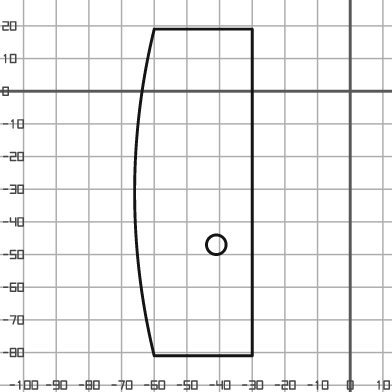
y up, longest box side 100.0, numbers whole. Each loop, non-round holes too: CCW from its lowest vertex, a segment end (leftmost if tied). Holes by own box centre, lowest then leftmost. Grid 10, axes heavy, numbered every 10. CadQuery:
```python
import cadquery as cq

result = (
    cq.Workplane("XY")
    .moveTo(-60.0, -81.0)
    .lineTo(-30.0, -81.0)
    .lineTo(-30.0, 19.0)
    .lineTo(-60.0, 19.0)
    .threePointArc((-66.0, -31.0), (-60.0, -81.0))
    .close()
    .moveTo(-41.0, -47.0)
    .circle(3.0)
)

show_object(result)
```